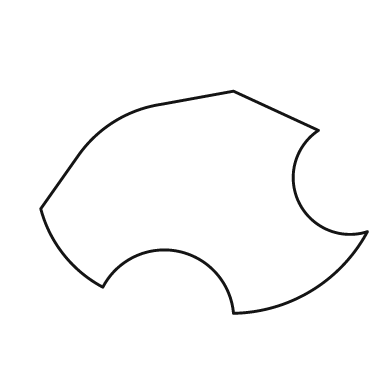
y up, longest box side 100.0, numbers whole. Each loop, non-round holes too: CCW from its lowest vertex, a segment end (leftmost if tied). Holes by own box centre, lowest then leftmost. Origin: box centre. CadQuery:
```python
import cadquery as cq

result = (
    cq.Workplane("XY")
    .moveTo(9.0, -34.0)
    .threePointArc((33.0, -27.0), (50.0, -9.0))
    .threePointArc((29.0, 0.0), (35.0, 22.0))
    .lineTo(9.0, 34.0)
    .lineTo(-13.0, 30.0)
    .threePointArc((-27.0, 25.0), (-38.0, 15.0))
    .lineTo(-50.0, -2.0)
    .threePointArc((-43.0, -16.0), (-31.0, -26.0))
    .threePointArc((-8.0, -15.0), (9.0, -34.0))
    .close()
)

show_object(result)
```